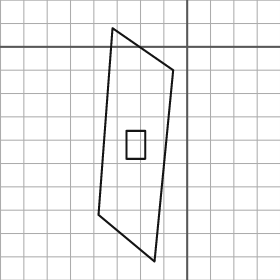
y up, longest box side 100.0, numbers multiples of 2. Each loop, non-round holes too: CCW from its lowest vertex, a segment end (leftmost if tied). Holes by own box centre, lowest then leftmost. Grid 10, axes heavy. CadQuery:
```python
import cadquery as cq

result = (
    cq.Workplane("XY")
    .moveTo(-14.0, -92.0)
    .lineTo(-6.0, -10.0)
    .lineTo(-32.0, 8.0)
    .lineTo(-38.0, -72.0)
    .close()
    .moveTo(-26.0, -48.0)
    .lineTo(-18.0, -48.0)
    .lineTo(-18.0, -36.0)
    .lineTo(-26.0, -36.0)
    .close()
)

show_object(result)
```